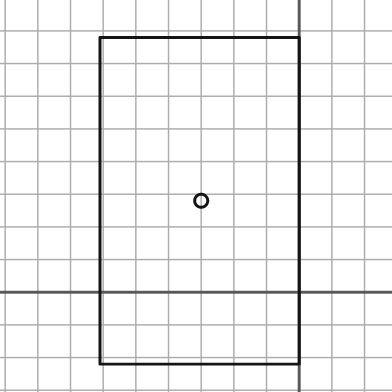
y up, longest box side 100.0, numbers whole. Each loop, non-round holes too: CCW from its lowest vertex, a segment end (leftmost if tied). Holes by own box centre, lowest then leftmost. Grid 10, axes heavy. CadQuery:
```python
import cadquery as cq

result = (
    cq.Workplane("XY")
    .moveTo(-61.0, -22.0)
    .lineTo(0.0, -22.0)
    .lineTo(0.0, 78.0)
    .lineTo(-61.0, 78.0)
    .close()
    .moveTo(-30.0, 28.0)
    .circle(2.0)
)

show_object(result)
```